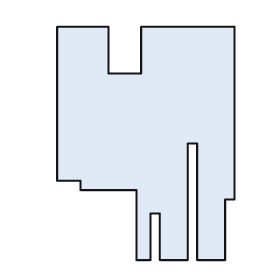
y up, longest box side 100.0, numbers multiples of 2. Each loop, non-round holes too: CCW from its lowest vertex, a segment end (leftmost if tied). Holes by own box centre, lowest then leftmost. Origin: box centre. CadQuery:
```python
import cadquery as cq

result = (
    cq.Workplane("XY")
    .moveTo(-4.0, -50.0)
    .lineTo(2.0, -50.0)
    .lineTo(2.0, -30.0)
    .lineTo(6.0, -30.0)
    .lineTo(6.0, -50.0)
    .lineTo(18.0, -50.0)
    .lineTo(18.0, 0.0)
    .lineTo(22.0, 0.0)
    .lineTo(22.0, -50.0)
    .lineTo(34.0, -50.0)
    .lineTo(34.0, -24.0)
    .lineTo(38.0, -24.0)
    .lineTo(38.0, 50.0)
    .lineTo(-2.0, 50.0)
    .lineTo(-2.0, 30.0)
    .lineTo(-16.0, 30.0)
    .lineTo(-16.0, 50.0)
    .lineTo(-38.0, 50.0)
    .lineTo(-38.0, -16.0)
    .lineTo(-28.0, -16.0)
    .lineTo(-28.0, -20.0)
    .lineTo(-4.0, -20.0)
    .close()
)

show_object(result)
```